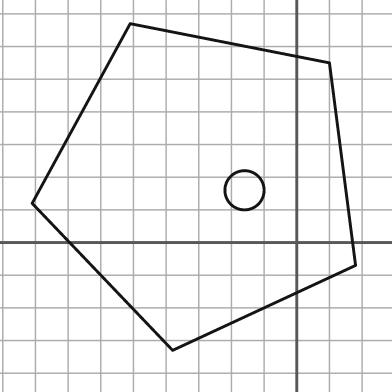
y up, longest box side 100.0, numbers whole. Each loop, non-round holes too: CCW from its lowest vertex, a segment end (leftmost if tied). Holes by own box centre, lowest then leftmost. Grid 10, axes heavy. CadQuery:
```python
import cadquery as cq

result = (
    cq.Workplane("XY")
    .moveTo(-38.0, -33.0)
    .lineTo(18.0, -7.0)
    .lineTo(10.0, 55.0)
    .lineTo(-51.0, 67.0)
    .lineTo(-81.0, 12.0)
    .close()
    .moveTo(-16.0, 16.0)
    .circle(6.0)
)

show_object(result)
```